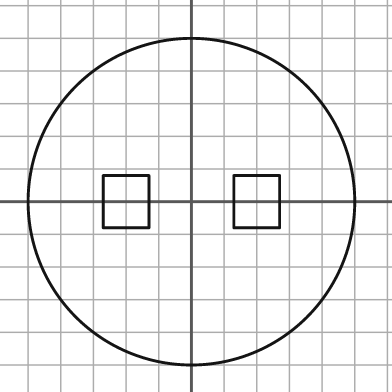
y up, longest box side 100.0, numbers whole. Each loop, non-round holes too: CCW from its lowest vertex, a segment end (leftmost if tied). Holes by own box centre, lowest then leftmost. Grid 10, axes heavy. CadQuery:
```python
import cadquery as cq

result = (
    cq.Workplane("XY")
    .moveTo(0.0, 0.0)
    .circle(50.0)
    .moveTo(-27.0, -8.0)
    .lineTo(-13.0, -8.0)
    .lineTo(-13.0, 8.0)
    .lineTo(-27.0, 8.0)
    .close()
    .moveTo(13.0, -8.0)
    .lineTo(27.0, -8.0)
    .lineTo(27.0, 8.0)
    .lineTo(13.0, 8.0)
    .close()
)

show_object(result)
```